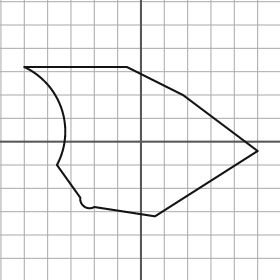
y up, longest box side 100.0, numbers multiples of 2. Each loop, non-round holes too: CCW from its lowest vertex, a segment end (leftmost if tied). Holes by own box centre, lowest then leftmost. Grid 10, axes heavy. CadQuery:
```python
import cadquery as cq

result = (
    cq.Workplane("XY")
    .moveTo(6.0, -32.0)
    .lineTo(50.0, -4.0)
    .lineTo(18.0, 20.0)
    .lineTo(-6.0, 32.0)
    .lineTo(-50.0, 32.0)
    .threePointArc((-34.0, 14.0), (-36.0, -10.0))
    .lineTo(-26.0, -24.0)
    .threePointArc((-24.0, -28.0), (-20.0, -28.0))
    .close()
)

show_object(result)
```